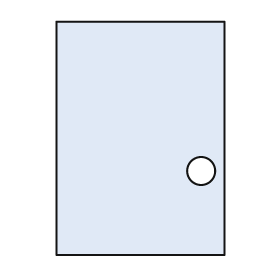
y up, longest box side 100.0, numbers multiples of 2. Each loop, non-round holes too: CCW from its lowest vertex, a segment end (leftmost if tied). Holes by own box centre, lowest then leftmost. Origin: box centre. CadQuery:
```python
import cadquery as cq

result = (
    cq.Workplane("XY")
    .moveTo(-36.0, -50.0)
    .lineTo(36.0, -50.0)
    .lineTo(36.0, 50.0)
    .lineTo(-36.0, 50.0)
    .close()
    .moveTo(26.0, -14.0)
    .circle(6.0)
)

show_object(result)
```